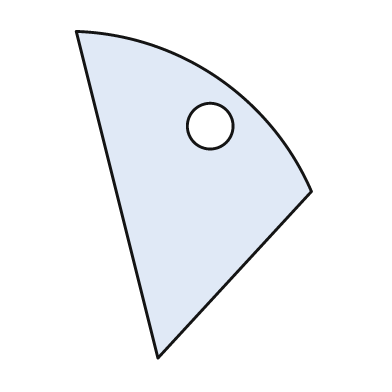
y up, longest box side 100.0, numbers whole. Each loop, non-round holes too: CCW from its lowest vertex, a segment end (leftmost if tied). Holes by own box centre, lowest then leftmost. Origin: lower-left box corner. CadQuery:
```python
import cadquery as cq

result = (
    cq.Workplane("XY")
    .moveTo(25.0, 0.0)
    .lineTo(72.0, 51.0)
    .threePointArc((43.0, 86.0), (0.0, 100.0))
    .close()
    .moveTo(41.0, 71.0)
    .circle(7.0)
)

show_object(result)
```